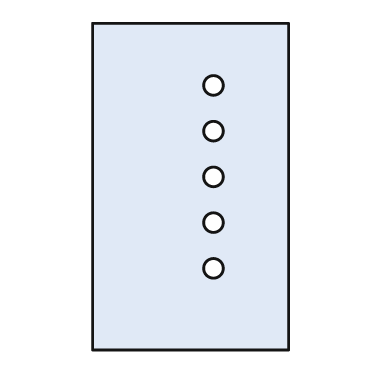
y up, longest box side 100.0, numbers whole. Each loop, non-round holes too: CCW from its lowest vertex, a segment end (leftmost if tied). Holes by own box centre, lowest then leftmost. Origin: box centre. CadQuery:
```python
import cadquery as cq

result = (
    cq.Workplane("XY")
    .moveTo(-30.0, -50.0)
    .lineTo(30.0, -50.0)
    .lineTo(30.0, 50.0)
    .lineTo(-30.0, 50.0)
    .close()
    .moveTo(7.0, -25.0)
    .circle(3.0)
    .moveTo(7.0, -11.0)
    .circle(3.0)
    .moveTo(7.0, 3.0)
    .circle(3.0)
    .moveTo(7.0, 17.0)
    .circle(3.0)
    .moveTo(7.0, 31.0)
    .circle(3.0)
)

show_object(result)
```